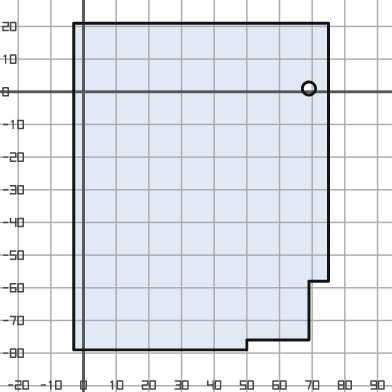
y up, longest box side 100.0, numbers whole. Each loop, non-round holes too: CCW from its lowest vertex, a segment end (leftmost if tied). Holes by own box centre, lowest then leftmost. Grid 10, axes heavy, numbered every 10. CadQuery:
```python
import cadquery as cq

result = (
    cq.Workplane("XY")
    .moveTo(-3.0, -79.0)
    .lineTo(50.0, -79.0)
    .lineTo(50.0, -76.0)
    .lineTo(69.0, -76.0)
    .lineTo(69.0, -58.0)
    .lineTo(75.0, -58.0)
    .lineTo(75.0, 21.0)
    .lineTo(-3.0, 21.0)
    .close()
    .moveTo(69.0, 1.0)
    .circle(2.0)
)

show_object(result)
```